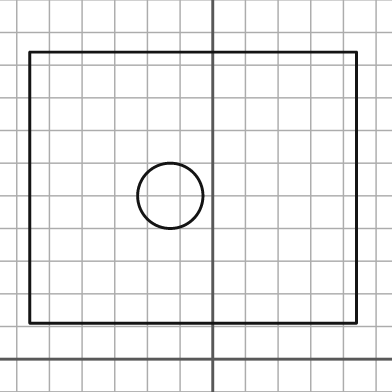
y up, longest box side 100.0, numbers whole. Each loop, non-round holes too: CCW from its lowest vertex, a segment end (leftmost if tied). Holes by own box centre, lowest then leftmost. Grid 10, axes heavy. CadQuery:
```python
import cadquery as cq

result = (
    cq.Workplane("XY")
    .moveTo(-56.0, 11.0)
    .lineTo(44.0, 11.0)
    .lineTo(44.0, 94.0)
    .lineTo(-56.0, 94.0)
    .close()
    .moveTo(-13.0, 50.0)
    .circle(10.0)
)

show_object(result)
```